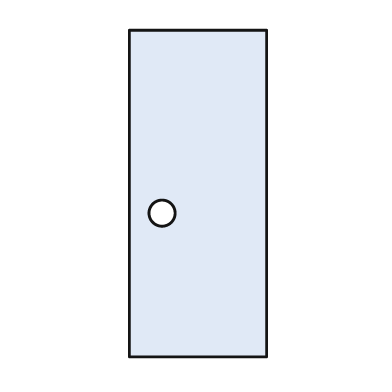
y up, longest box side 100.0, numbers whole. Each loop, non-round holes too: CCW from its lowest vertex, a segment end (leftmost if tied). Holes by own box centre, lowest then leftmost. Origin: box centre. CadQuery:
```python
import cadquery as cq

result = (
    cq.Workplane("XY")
    .moveTo(-21.0, -50.0)
    .lineTo(21.0, -50.0)
    .lineTo(21.0, 50.0)
    .lineTo(-21.0, 50.0)
    .close()
    .moveTo(-11.0, -6.0)
    .circle(4.0)
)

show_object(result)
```